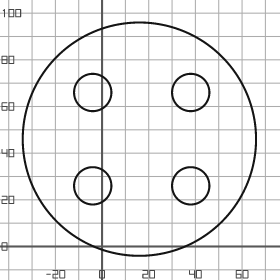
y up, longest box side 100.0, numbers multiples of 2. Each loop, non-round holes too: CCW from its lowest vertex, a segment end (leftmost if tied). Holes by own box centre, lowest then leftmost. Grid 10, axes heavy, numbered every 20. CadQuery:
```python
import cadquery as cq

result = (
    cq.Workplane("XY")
    .moveTo(16.0, 46.0)
    .circle(50.0)
    .moveTo(-4.0, 26.0)
    .circle(8.0)
    .moveTo(38.0, 26.0)
    .circle(8.0)
    .moveTo(-4.0, 66.0)
    .circle(8.0)
    .moveTo(38.0, 66.0)
    .circle(8.0)
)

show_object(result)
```